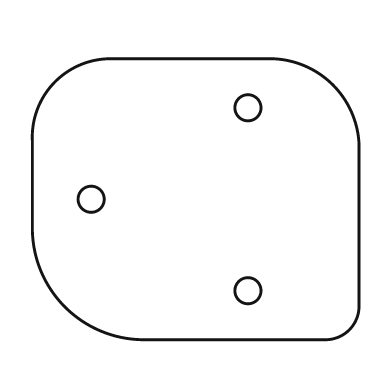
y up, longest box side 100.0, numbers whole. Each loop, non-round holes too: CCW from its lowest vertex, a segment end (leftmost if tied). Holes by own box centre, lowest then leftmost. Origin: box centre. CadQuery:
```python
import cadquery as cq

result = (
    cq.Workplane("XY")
    .moveTo(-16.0, -43.0)
    .lineTo(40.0, -43.0)
    .threePointArc((47.0, -40.0), (50.0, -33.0))
    .lineTo(50.0, 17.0)
    .threePointArc((42.0, 35.0), (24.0, 43.0))
    .lineTo(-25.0, 43.0)
    .threePointArc((-43.0, 36.0), (-50.0, 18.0))
    .lineTo(-50.0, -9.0)
    .threePointArc((-40.0, -33.0), (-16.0, -43.0))
    .close()
    .moveTo(16.0, -28.0)
    .circle(4.0)
    .moveTo(-32.0, 0.0)
    .circle(4.0)
    .moveTo(16.0, 28.0)
    .circle(4.0)
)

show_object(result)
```